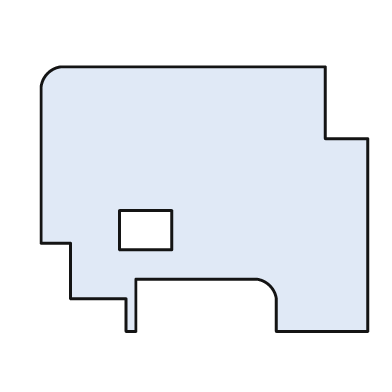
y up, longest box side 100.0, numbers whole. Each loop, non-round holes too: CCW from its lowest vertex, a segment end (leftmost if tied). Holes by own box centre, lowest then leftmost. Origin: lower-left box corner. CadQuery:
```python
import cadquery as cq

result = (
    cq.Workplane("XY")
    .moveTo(26.0, 0.0)
    .lineTo(29.0, 0.0)
    .lineTo(29.0, 16.0)
    .lineTo(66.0, 16.0)
    .threePointArc((70.0, 14.0), (72.0, 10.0))
    .lineTo(72.0, 0.0)
    .lineTo(100.0, 0.0)
    .lineTo(100.0, 59.0)
    .lineTo(87.0, 59.0)
    .lineTo(87.0, 81.0)
    .lineTo(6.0, 81.0)
    .threePointArc((2.0, 79.0), (0.0, 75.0))
    .lineTo(0.0, 27.0)
    .lineTo(9.0, 27.0)
    .lineTo(9.0, 10.0)
    .lineTo(26.0, 10.0)
    .close()
    .moveTo(24.0, 25.0)
    .lineTo(40.0, 25.0)
    .lineTo(40.0, 37.0)
    .lineTo(24.0, 37.0)
    .close()
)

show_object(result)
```